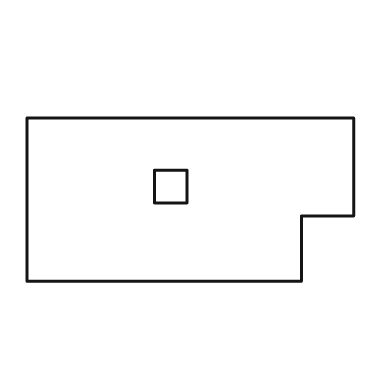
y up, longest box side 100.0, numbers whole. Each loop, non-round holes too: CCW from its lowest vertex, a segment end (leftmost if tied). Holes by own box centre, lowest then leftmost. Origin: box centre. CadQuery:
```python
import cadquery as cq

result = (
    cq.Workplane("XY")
    .moveTo(-50.0, -25.0)
    .lineTo(34.0, -25.0)
    .lineTo(34.0, -5.0)
    .lineTo(50.0, -5.0)
    .lineTo(50.0, 25.0)
    .lineTo(-50.0, 25.0)
    .close()
    .moveTo(-11.0, -1.0)
    .lineTo(-1.0, -1.0)
    .lineTo(-1.0, 9.0)
    .lineTo(-11.0, 9.0)
    .close()
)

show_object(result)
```